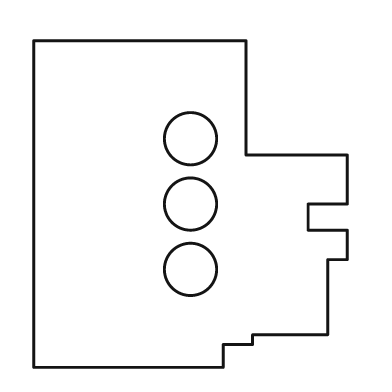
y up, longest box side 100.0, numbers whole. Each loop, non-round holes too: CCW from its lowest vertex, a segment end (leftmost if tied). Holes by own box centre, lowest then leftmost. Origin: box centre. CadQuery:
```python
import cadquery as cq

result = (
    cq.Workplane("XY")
    .moveTo(-48.0, -50.0)
    .lineTo(10.0, -50.0)
    .lineTo(10.0, -43.0)
    .lineTo(19.0, -43.0)
    .lineTo(19.0, -40.0)
    .lineTo(42.0, -40.0)
    .lineTo(42.0, -17.0)
    .lineTo(48.0, -17.0)
    .lineTo(48.0, -8.0)
    .lineTo(36.0, -8.0)
    .lineTo(36.0, 0.0)
    .lineTo(48.0, 0.0)
    .lineTo(48.0, 15.0)
    .lineTo(17.0, 15.0)
    .lineTo(17.0, 50.0)
    .lineTo(-48.0, 50.0)
    .close()
    .moveTo(0.0, -20.0)
    .circle(8.0)
    .moveTo(0.0, 0.0)
    .circle(8.0)
    .moveTo(0.0, 20.0)
    .circle(8.0)
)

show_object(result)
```